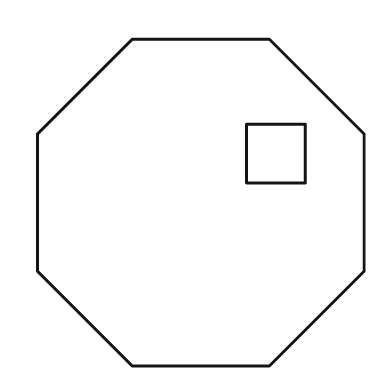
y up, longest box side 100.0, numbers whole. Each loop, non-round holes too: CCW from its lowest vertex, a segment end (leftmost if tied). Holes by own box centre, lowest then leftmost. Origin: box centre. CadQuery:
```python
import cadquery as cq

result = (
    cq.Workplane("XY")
    .moveTo(-21.0, -50.0)
    .lineTo(21.0, -50.0)
    .lineTo(50.0, -21.0)
    .lineTo(50.0, 21.0)
    .lineTo(21.0, 50.0)
    .lineTo(-21.0, 50.0)
    .lineTo(-50.0, 21.0)
    .lineTo(-50.0, -21.0)
    .close()
    .moveTo(14.0, 6.0)
    .lineTo(32.0, 6.0)
    .lineTo(32.0, 24.0)
    .lineTo(14.0, 24.0)
    .close()
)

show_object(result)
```